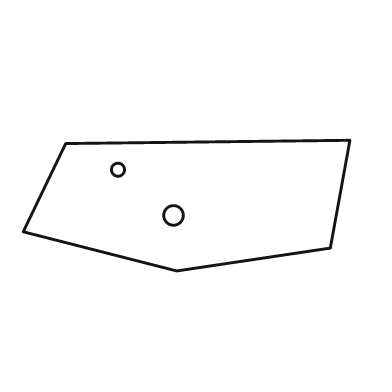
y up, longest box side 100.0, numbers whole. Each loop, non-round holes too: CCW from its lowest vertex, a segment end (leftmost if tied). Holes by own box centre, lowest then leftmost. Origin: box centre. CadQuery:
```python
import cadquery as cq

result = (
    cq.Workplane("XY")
    .moveTo(-3.0, -20.0)
    .lineTo(44.0, -13.0)
    .lineTo(50.0, 20.0)
    .lineTo(-37.0, 19.0)
    .lineTo(-50.0, -8.0)
    .close()
    .moveTo(-4.0, -3.0)
    .circle(3.0)
    .moveTo(-21.0, 11.0)
    .circle(2.0)
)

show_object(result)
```